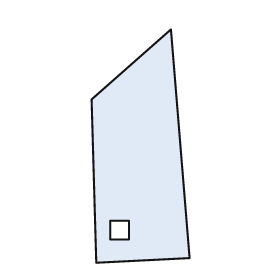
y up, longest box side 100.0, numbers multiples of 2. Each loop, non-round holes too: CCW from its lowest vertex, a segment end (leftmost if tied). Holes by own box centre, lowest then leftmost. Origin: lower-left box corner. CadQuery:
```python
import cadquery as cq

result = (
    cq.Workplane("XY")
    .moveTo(2.0, 0.0)
    .lineTo(42.0, 2.0)
    .lineTo(34.0, 100.0)
    .lineTo(0.0, 70.0)
    .close()
    .moveTo(8.0, 10.0)
    .lineTo(16.0, 10.0)
    .lineTo(16.0, 18.0)
    .lineTo(8.0, 18.0)
    .close()
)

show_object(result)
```